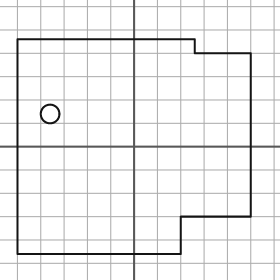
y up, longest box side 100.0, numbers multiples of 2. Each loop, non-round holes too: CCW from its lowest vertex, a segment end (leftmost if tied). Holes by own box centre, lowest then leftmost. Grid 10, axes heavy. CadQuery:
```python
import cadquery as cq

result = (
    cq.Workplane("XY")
    .moveTo(-50.0, -46.0)
    .lineTo(20.0, -46.0)
    .lineTo(20.0, -30.0)
    .lineTo(50.0, -30.0)
    .lineTo(50.0, 40.0)
    .lineTo(26.0, 40.0)
    .lineTo(26.0, 46.0)
    .lineTo(-50.0, 46.0)
    .close()
    .moveTo(-36.0, 14.0)
    .circle(4.0)
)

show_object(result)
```